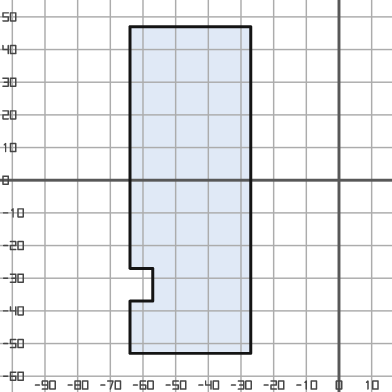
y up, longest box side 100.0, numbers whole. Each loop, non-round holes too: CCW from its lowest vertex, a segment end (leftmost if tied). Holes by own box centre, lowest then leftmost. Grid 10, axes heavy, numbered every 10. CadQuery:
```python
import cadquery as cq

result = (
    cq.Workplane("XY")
    .moveTo(-64.0, -53.0)
    .lineTo(-27.0, -53.0)
    .lineTo(-27.0, 47.0)
    .lineTo(-64.0, 47.0)
    .lineTo(-64.0, -27.0)
    .lineTo(-57.0, -27.0)
    .lineTo(-57.0, -37.0)
    .lineTo(-64.0, -37.0)
    .close()
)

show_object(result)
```